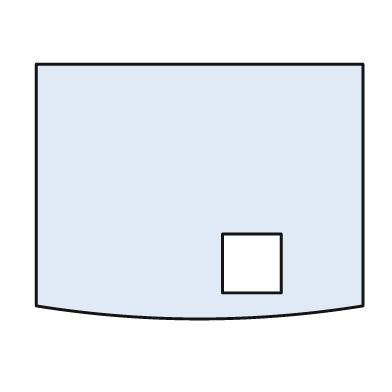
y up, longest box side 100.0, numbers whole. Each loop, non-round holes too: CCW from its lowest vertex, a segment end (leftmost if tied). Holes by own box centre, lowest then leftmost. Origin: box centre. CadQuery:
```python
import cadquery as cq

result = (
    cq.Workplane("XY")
    .moveTo(-50.0, -35.0)
    .threePointArc((0.0, -39.0), (50.0, -35.0))
    .lineTo(50.0, 39.0)
    .lineTo(-50.0, 39.0)
    .close()
    .moveTo(7.0, -31.0)
    .lineTo(25.0, -31.0)
    .lineTo(25.0, -13.0)
    .lineTo(7.0, -13.0)
    .close()
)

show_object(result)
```